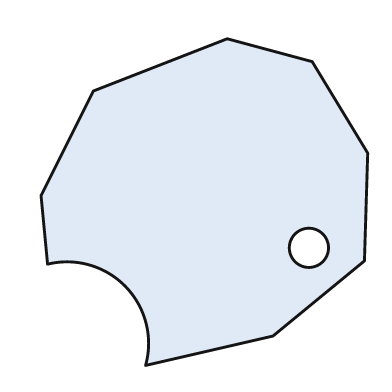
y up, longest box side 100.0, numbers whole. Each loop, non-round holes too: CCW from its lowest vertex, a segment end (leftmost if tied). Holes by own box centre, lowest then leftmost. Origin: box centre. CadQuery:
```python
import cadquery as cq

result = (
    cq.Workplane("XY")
    .moveTo(-18.0, -50.0)
    .lineTo(21.0, -41.0)
    .lineTo(49.0, -18.0)
    .lineTo(50.0, 15.0)
    .lineTo(33.0, 43.0)
    .lineTo(7.0, 50.0)
    .lineTo(-34.0, 34.0)
    .lineTo(-50.0, 2.0)
    .lineTo(-48.0, -19.0)
    .threePointArc((-24.0, -26.0), (-18.0, -50.0))
    .close()
    .moveTo(32.0, -14.0)
    .circle(6.0)
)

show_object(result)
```